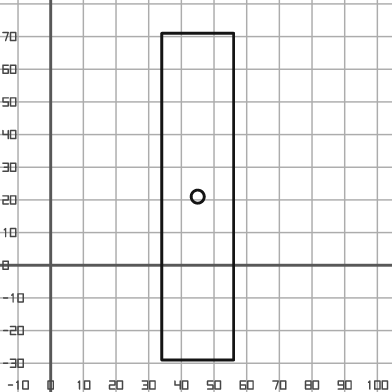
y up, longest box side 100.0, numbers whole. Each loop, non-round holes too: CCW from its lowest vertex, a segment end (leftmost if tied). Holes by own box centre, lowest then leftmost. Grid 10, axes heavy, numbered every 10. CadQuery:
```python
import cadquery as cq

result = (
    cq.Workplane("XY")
    .moveTo(34.0, -29.0)
    .lineTo(56.0, -29.0)
    .lineTo(56.0, 71.0)
    .lineTo(34.0, 71.0)
    .close()
    .moveTo(45.0, 21.0)
    .circle(2.0)
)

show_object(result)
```